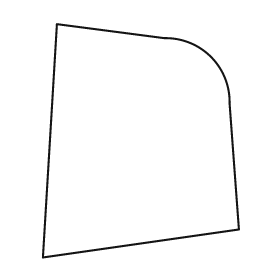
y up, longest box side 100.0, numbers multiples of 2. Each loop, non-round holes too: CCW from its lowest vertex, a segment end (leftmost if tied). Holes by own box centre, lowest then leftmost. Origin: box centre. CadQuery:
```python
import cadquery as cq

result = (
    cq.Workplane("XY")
    .moveTo(-42.0, -50.0)
    .lineTo(42.0, -38.0)
    .lineTo(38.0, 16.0)
    .threePointArc((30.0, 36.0), (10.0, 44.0))
    .lineTo(-36.0, 50.0)
    .close()
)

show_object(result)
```